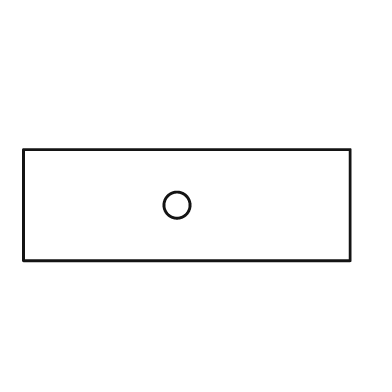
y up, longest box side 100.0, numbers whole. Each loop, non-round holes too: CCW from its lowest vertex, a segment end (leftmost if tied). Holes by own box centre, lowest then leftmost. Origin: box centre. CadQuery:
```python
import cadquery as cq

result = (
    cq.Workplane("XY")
    .moveTo(-50.0, -17.0)
    .lineTo(50.0, -17.0)
    .lineTo(50.0, 17.0)
    .lineTo(-50.0, 17.0)
    .close()
    .moveTo(-3.0, 0.0)
    .circle(4.0)
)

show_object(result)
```